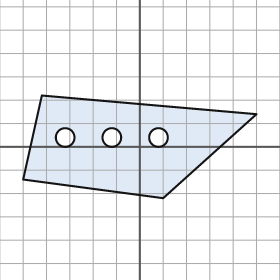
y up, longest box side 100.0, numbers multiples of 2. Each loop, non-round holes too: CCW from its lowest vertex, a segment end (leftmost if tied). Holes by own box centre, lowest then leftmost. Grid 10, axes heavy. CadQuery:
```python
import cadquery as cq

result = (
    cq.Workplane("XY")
    .moveTo(10.0, -22.0)
    .lineTo(50.0, 14.0)
    .lineTo(-42.0, 22.0)
    .lineTo(-50.0, -14.0)
    .close()
    .moveTo(-32.0, 4.0)
    .circle(4.0)
    .moveTo(-12.0, 4.0)
    .circle(4.0)
    .moveTo(8.0, 4.0)
    .circle(4.0)
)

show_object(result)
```